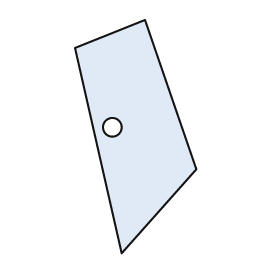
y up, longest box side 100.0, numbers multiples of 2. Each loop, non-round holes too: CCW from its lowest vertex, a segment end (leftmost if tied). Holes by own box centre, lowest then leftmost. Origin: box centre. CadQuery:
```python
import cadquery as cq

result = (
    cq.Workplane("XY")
    .moveTo(-6.0, -50.0)
    .lineTo(26.0, -14.0)
    .lineTo(4.0, 50.0)
    .lineTo(-26.0, 38.0)
    .close()
    .moveTo(-10.0, 4.0)
    .circle(4.0)
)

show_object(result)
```